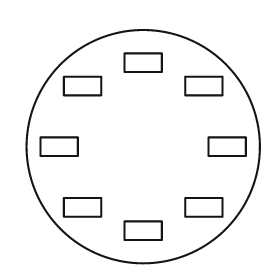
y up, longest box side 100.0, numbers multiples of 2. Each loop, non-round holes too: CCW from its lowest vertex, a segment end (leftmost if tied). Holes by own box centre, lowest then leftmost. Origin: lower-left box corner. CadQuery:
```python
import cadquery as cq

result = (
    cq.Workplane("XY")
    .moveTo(50.0, 50.0)
    .circle(50.0)
    .moveTo(42.0, 10.0)
    .lineTo(58.0, 10.0)
    .lineTo(58.0, 18.0)
    .lineTo(42.0, 18.0)
    .close()
    .moveTo(16.0, 20.0)
    .lineTo(32.0, 20.0)
    .lineTo(32.0, 28.0)
    .lineTo(16.0, 28.0)
    .close()
    .moveTo(68.0, 20.0)
    .lineTo(84.0, 20.0)
    .lineTo(84.0, 28.0)
    .lineTo(68.0, 28.0)
    .close()
    .moveTo(6.0, 46.0)
    .lineTo(22.0, 46.0)
    .lineTo(22.0, 54.0)
    .lineTo(6.0, 54.0)
    .close()
    .moveTo(78.0, 46.0)
    .lineTo(94.0, 46.0)
    .lineTo(94.0, 54.0)
    .lineTo(78.0, 54.0)
    .close()
    .moveTo(16.0, 72.0)
    .lineTo(32.0, 72.0)
    .lineTo(32.0, 80.0)
    .lineTo(16.0, 80.0)
    .close()
    .moveTo(68.0, 72.0)
    .lineTo(84.0, 72.0)
    .lineTo(84.0, 80.0)
    .lineTo(68.0, 80.0)
    .close()
    .moveTo(42.0, 82.0)
    .lineTo(58.0, 82.0)
    .lineTo(58.0, 90.0)
    .lineTo(42.0, 90.0)
    .close()
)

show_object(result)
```